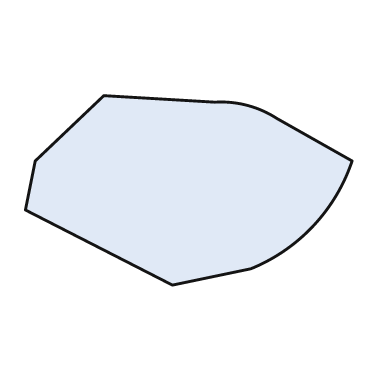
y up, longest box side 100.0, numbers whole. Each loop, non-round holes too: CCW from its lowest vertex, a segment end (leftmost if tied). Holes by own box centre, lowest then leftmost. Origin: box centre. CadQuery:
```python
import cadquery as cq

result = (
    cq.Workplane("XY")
    .moveTo(-5.0, -29.0)
    .lineTo(19.0, -24.0)
    .threePointArc((38.0, -11.0), (50.0, 9.0))
    .lineTo(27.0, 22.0)
    .threePointArc((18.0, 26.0), (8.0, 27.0))
    .lineTo(-26.0, 29.0)
    .lineTo(-47.0, 9.0)
    .lineTo(-50.0, -6.0)
    .close()
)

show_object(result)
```